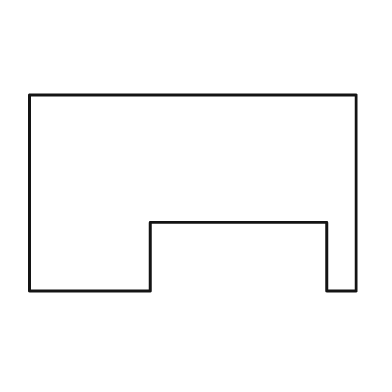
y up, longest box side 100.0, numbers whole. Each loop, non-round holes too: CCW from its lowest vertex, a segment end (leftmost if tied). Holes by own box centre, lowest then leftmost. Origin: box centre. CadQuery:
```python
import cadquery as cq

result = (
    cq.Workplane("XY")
    .moveTo(-50.0, -30.0)
    .lineTo(-13.0, -30.0)
    .lineTo(-13.0, -9.0)
    .lineTo(41.0, -9.0)
    .lineTo(41.0, -30.0)
    .lineTo(50.0, -30.0)
    .lineTo(50.0, 30.0)
    .lineTo(-50.0, 30.0)
    .close()
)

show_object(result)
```